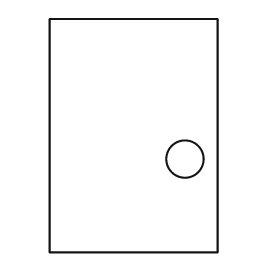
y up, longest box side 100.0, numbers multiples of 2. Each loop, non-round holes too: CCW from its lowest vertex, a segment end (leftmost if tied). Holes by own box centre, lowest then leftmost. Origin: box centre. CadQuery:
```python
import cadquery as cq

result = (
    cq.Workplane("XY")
    .moveTo(-36.0, -50.0)
    .lineTo(36.0, -50.0)
    .lineTo(36.0, 50.0)
    .lineTo(-36.0, 50.0)
    .close()
    .moveTo(22.0, -10.0)
    .circle(8.0)
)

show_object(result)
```